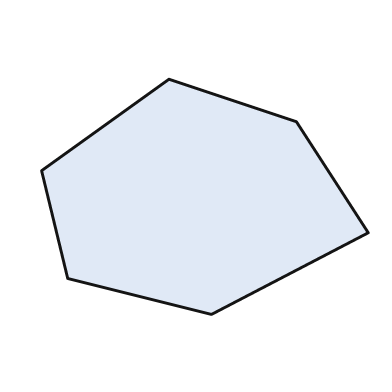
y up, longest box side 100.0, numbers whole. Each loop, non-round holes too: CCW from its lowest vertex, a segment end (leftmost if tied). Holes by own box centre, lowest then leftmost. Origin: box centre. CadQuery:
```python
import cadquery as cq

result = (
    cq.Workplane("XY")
    .moveTo(2.0, -36.0)
    .lineTo(50.0, -11.0)
    .lineTo(28.0, 23.0)
    .lineTo(-11.0, 36.0)
    .lineTo(-50.0, 8.0)
    .lineTo(-42.0, -25.0)
    .close()
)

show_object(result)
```